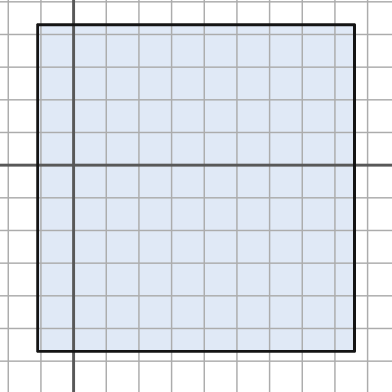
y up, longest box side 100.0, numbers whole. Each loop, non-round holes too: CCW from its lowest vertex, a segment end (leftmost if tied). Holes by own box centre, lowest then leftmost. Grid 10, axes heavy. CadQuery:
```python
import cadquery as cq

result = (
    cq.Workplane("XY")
    .moveTo(-11.0, -57.0)
    .lineTo(86.0, -57.0)
    .lineTo(86.0, 43.0)
    .lineTo(-11.0, 43.0)
    .close()
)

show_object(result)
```